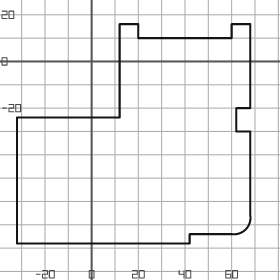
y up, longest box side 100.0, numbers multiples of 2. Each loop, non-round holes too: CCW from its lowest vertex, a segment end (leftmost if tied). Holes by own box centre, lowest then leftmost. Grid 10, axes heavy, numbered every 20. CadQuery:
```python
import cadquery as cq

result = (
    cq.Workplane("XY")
    .moveTo(-32.0, -78.0)
    .lineTo(42.0, -78.0)
    .lineTo(42.0, -74.0)
    .lineTo(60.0, -74.0)
    .threePointArc((66.0, -72.0), (68.0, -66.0))
    .lineTo(68.0, -30.0)
    .lineTo(62.0, -30.0)
    .lineTo(62.0, -20.0)
    .lineTo(68.0, -20.0)
    .lineTo(68.0, 16.0)
    .lineTo(60.0, 16.0)
    .lineTo(60.0, 10.0)
    .lineTo(20.0, 10.0)
    .lineTo(20.0, 16.0)
    .lineTo(12.0, 16.0)
    .lineTo(12.0, -24.0)
    .lineTo(-32.0, -24.0)
    .close()
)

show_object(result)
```